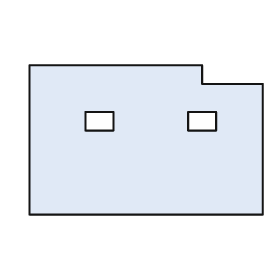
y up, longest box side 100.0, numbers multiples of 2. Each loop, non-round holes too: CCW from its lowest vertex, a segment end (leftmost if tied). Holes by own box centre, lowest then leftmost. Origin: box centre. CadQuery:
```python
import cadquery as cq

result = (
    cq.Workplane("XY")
    .moveTo(-50.0, -32.0)
    .lineTo(50.0, -32.0)
    .lineTo(50.0, 24.0)
    .lineTo(24.0, 24.0)
    .lineTo(24.0, 32.0)
    .lineTo(-50.0, 32.0)
    .close()
    .moveTo(-26.0, 4.0)
    .lineTo(-14.0, 4.0)
    .lineTo(-14.0, 12.0)
    .lineTo(-26.0, 12.0)
    .close()
    .moveTo(18.0, 4.0)
    .lineTo(30.0, 4.0)
    .lineTo(30.0, 12.0)
    .lineTo(18.0, 12.0)
    .close()
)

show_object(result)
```